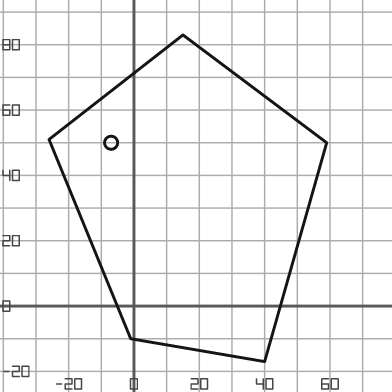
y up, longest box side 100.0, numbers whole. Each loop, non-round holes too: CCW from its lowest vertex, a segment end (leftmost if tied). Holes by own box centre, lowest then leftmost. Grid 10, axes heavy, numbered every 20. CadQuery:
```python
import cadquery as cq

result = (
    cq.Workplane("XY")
    .moveTo(40.0, -17.0)
    .lineTo(59.0, 50.0)
    .lineTo(15.0, 83.0)
    .lineTo(-26.0, 51.0)
    .lineTo(-1.0, -10.0)
    .close()
    .moveTo(-7.0, 50.0)
    .circle(2.0)
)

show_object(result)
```